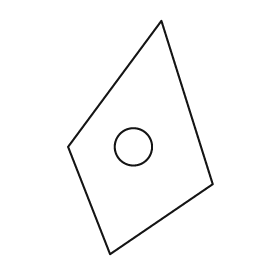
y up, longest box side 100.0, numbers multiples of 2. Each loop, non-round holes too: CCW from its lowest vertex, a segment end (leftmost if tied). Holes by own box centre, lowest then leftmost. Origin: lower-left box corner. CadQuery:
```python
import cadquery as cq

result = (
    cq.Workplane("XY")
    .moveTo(18.0, 0.0)
    .lineTo(62.0, 30.0)
    .lineTo(40.0, 100.0)
    .lineTo(0.0, 46.0)
    .close()
    .moveTo(28.0, 46.0)
    .circle(8.0)
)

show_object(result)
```